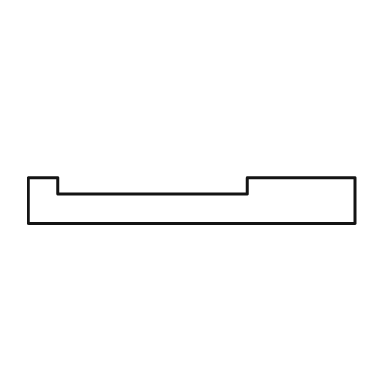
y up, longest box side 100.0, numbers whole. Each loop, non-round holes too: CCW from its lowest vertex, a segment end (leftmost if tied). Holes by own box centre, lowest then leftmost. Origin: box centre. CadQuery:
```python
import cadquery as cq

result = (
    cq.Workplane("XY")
    .moveTo(-50.0, -7.0)
    .lineTo(50.0, -7.0)
    .lineTo(50.0, 7.0)
    .lineTo(17.0, 7.0)
    .lineTo(17.0, 2.0)
    .lineTo(-41.0, 2.0)
    .lineTo(-41.0, 7.0)
    .lineTo(-50.0, 7.0)
    .close()
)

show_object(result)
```